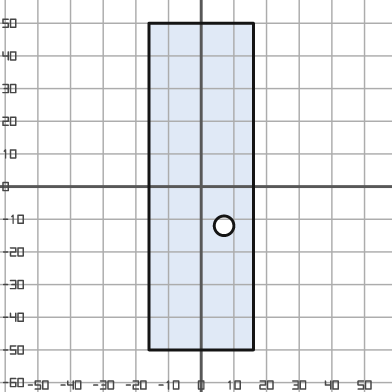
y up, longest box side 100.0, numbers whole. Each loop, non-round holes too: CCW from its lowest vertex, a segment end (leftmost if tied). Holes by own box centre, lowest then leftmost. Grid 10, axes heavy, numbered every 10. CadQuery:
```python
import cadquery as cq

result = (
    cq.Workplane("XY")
    .moveTo(-16.0, -50.0)
    .lineTo(16.0, -50.0)
    .lineTo(16.0, 50.0)
    .lineTo(-16.0, 50.0)
    .close()
    .moveTo(7.0, -12.0)
    .circle(3.0)
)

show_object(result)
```